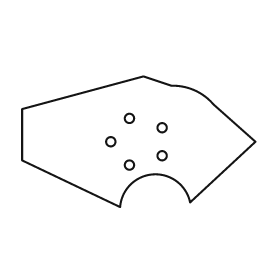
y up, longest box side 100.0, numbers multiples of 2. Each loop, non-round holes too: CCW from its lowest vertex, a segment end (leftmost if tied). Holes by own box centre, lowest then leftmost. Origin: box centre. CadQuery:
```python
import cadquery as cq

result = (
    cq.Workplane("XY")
    .moveTo(-8.0, -28.0)
    .threePointArc((6.0, -14.0), (22.0, -26.0))
    .lineTo(50.0, 0.0)
    .lineTo(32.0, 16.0)
    .threePointArc((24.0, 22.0), (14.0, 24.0))
    .lineTo(2.0, 28.0)
    .lineTo(-50.0, 14.0)
    .lineTo(-50.0, -8.0)
    .close()
    .moveTo(-4.0, -10.0)
    .circle(2.0)
    .moveTo(10.0, -6.0)
    .circle(2.0)
    .moveTo(-12.0, 0.0)
    .circle(2.0)
    .moveTo(10.0, 6.0)
    .circle(2.0)
    .moveTo(-4.0, 10.0)
    .circle(2.0)
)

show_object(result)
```